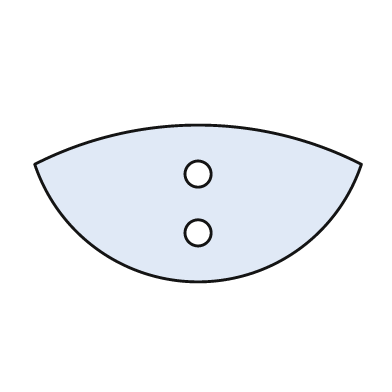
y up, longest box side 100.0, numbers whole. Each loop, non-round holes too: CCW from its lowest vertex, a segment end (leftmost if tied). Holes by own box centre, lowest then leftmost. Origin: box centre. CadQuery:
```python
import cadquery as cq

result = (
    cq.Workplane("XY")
    .moveTo(-50.0, 12.0)
    .threePointArc((0.0, -24.0), (50.0, 12.0))
    .threePointArc((0.0, 24.0), (-50.0, 12.0))
    .close()
    .moveTo(0.0, -9.0)
    .circle(4.0)
    .moveTo(0.0, 9.0)
    .circle(4.0)
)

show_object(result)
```